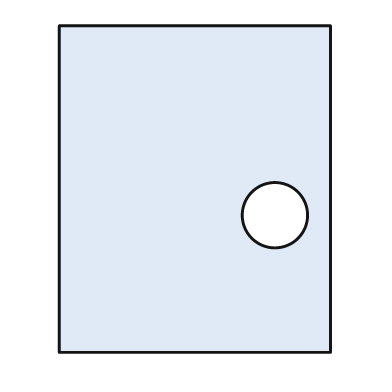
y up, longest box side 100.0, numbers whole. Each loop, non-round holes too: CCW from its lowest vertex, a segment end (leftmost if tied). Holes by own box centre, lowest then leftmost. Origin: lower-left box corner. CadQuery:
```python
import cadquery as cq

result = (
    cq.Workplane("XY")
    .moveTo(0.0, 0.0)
    .lineTo(83.0, 0.0)
    .lineTo(83.0, 100.0)
    .lineTo(0.0, 100.0)
    .close()
    .moveTo(66.0, 42.0)
    .circle(10.0)
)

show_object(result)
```